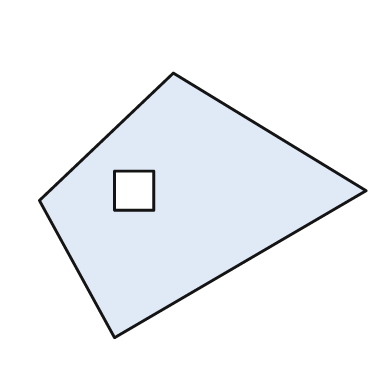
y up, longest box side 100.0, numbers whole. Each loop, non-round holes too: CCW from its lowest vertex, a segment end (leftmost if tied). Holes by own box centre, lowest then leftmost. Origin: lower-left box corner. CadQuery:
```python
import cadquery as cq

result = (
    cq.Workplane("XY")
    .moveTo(23.0, 0.0)
    .lineTo(100.0, 45.0)
    .lineTo(41.0, 81.0)
    .lineTo(0.0, 42.0)
    .close()
    .moveTo(23.0, 39.0)
    .lineTo(35.0, 39.0)
    .lineTo(35.0, 51.0)
    .lineTo(23.0, 51.0)
    .close()
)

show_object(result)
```